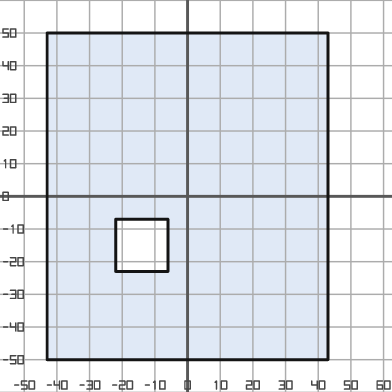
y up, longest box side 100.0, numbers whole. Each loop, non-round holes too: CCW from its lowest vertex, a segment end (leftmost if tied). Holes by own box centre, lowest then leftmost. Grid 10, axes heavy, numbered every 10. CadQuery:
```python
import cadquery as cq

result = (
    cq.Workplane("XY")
    .moveTo(-43.0, -50.0)
    .lineTo(43.0, -50.0)
    .lineTo(43.0, 50.0)
    .lineTo(-43.0, 50.0)
    .close()
    .moveTo(-22.0, -23.0)
    .lineTo(-6.0, -23.0)
    .lineTo(-6.0, -7.0)
    .lineTo(-22.0, -7.0)
    .close()
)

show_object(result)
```